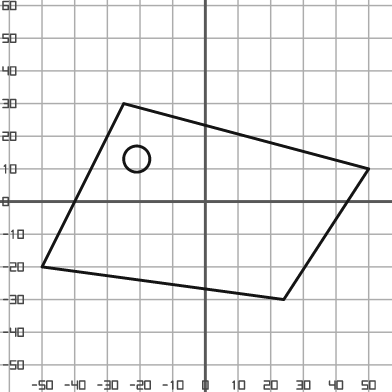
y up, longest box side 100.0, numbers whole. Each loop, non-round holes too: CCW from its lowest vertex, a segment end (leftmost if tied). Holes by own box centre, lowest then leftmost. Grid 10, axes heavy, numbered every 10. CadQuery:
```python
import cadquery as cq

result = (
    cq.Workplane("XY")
    .moveTo(24.0, -30.0)
    .lineTo(50.0, 10.0)
    .lineTo(-25.0, 30.0)
    .lineTo(-50.0, -20.0)
    .close()
    .moveTo(-21.0, 13.0)
    .circle(4.0)
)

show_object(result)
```